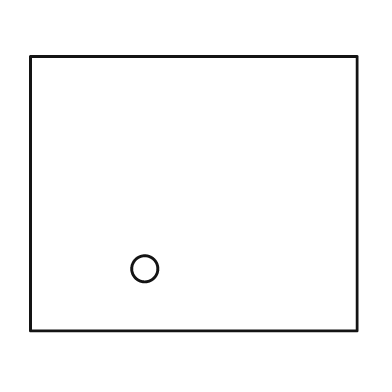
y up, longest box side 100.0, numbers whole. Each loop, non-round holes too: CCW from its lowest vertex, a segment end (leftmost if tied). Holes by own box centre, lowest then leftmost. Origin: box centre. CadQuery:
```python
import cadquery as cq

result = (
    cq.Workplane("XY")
    .moveTo(-50.0, -42.0)
    .lineTo(50.0, -42.0)
    .lineTo(50.0, 42.0)
    .lineTo(-50.0, 42.0)
    .close()
    .moveTo(-15.0, -23.0)
    .circle(4.0)
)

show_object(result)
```